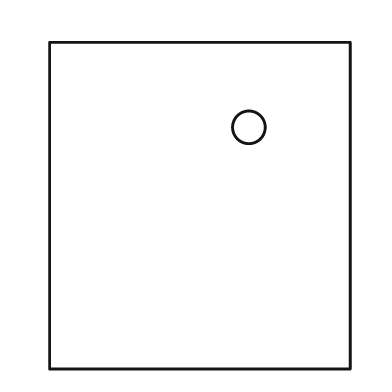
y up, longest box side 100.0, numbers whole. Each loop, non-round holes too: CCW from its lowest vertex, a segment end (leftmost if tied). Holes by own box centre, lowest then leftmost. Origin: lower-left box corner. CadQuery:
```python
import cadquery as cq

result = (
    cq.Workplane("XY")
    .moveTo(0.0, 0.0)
    .lineTo(92.0, 0.0)
    .lineTo(92.0, 100.0)
    .lineTo(0.0, 100.0)
    .close()
    .moveTo(61.0, 74.0)
    .circle(5.0)
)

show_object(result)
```